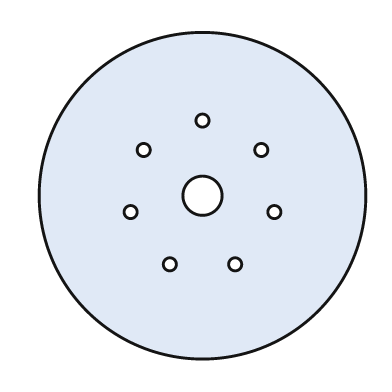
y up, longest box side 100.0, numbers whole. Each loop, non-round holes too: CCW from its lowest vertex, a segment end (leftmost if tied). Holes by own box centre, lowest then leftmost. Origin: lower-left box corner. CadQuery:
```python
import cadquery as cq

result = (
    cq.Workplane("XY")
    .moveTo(50.0, 50.0)
    .circle(50.0)
    .moveTo(40.0, 29.0)
    .circle(2.0)
    .moveTo(60.0, 29.0)
    .circle(2.0)
    .moveTo(28.0, 45.0)
    .circle(2.0)
    .moveTo(72.0, 45.0)
    .circle(2.0)
    .moveTo(50.0, 50.0)
    .circle(6.0)
    .moveTo(32.0, 64.0)
    .circle(2.0)
    .moveTo(68.0, 64.0)
    .circle(2.0)
    .moveTo(50.0, 73.0)
    .circle(2.0)
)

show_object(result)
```